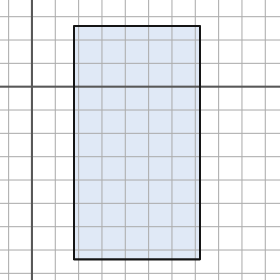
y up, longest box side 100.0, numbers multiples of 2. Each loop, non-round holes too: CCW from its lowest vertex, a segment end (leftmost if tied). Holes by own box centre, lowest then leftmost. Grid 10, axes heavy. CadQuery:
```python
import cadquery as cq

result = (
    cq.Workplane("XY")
    .moveTo(18.0, -74.0)
    .lineTo(72.0, -74.0)
    .lineTo(72.0, 26.0)
    .lineTo(18.0, 26.0)
    .close()
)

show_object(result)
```